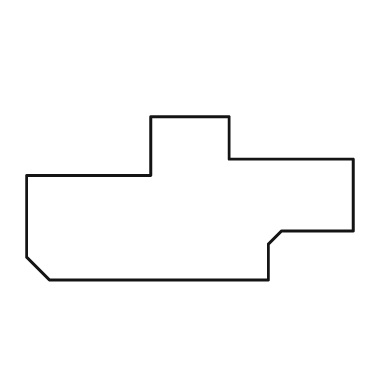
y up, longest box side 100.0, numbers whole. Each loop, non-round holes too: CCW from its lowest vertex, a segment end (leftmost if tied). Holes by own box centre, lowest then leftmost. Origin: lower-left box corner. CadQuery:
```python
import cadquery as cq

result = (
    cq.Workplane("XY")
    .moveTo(7.0, 0.0)
    .lineTo(74.0, 0.0)
    .lineTo(74.0, 11.0)
    .lineTo(78.0, 15.0)
    .lineTo(100.0, 15.0)
    .lineTo(100.0, 37.0)
    .lineTo(62.0, 37.0)
    .lineTo(62.0, 50.0)
    .lineTo(38.0, 50.0)
    .lineTo(38.0, 32.0)
    .lineTo(0.0, 32.0)
    .lineTo(0.0, 7.0)
    .close()
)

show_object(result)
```